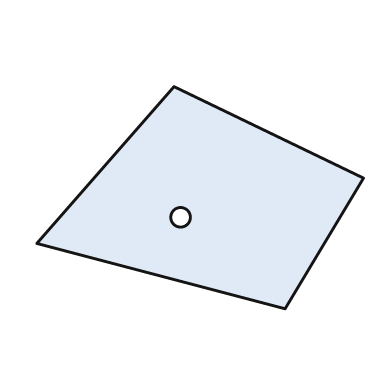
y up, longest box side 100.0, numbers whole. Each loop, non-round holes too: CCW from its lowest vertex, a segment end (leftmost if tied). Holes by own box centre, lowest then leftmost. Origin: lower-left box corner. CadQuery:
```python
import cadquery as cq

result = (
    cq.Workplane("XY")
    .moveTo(76.0, 0.0)
    .lineTo(100.0, 40.0)
    .lineTo(42.0, 68.0)
    .lineTo(0.0, 20.0)
    .close()
    .moveTo(44.0, 28.0)
    .circle(3.0)
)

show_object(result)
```